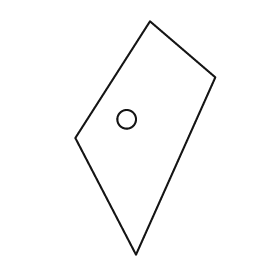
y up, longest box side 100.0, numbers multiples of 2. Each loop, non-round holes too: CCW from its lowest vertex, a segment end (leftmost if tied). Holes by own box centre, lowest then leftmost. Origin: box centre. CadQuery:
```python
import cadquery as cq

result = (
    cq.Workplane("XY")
    .moveTo(-4.0, -50.0)
    .lineTo(30.0, 26.0)
    .lineTo(2.0, 50.0)
    .lineTo(-30.0, 0.0)
    .close()
    .moveTo(-8.0, 8.0)
    .circle(4.0)
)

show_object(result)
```